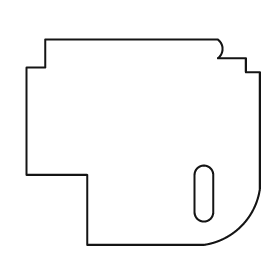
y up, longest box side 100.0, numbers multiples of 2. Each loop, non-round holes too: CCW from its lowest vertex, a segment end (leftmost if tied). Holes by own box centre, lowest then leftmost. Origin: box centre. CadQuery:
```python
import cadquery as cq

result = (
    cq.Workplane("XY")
    .moveTo(-24.0, -44.0)
    .lineTo(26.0, -44.0)
    .threePointArc((42.0, -36.0), (50.0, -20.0))
    .lineTo(50.0, 30.0)
    .lineTo(44.0, 30.0)
    .lineTo(44.0, 36.0)
    .lineTo(32.0, 36.0)
    .threePointArc((34.0, 40.0), (32.0, 44.0))
    .lineTo(-42.0, 44.0)
    .lineTo(-42.0, 32.0)
    .lineTo(-50.0, 32.0)
    .lineTo(-50.0, -14.0)
    .lineTo(-24.0, -14.0)
    .close()
    .moveTo(22.0, -30.0)
    .threePointArc((26.0, -34.0), (30.0, -30.0))
    .lineTo(30.0, -14.0)
    .threePointArc((26.0, -10.0), (22.0, -14.0))
    .close()
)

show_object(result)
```